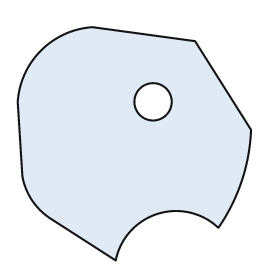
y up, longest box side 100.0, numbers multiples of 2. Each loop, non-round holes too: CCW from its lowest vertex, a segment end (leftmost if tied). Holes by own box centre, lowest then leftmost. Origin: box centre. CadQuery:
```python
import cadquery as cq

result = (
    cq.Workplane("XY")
    .moveTo(-8.0, -50.0)
    .threePointArc((10.0, -30.0), (36.0, -36.0))
    .threePointArc((46.0, -16.0), (50.0, 6.0))
    .lineTo(26.0, 44.0)
    .lineTo(-18.0, 50.0)
    .threePointArc((-40.0, 40.0), (-50.0, 18.0))
    .lineTo(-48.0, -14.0)
    .threePointArc((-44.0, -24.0), (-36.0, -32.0))
    .close()
    .moveTo(8.0, 18.0)
    .circle(8.0)
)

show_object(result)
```